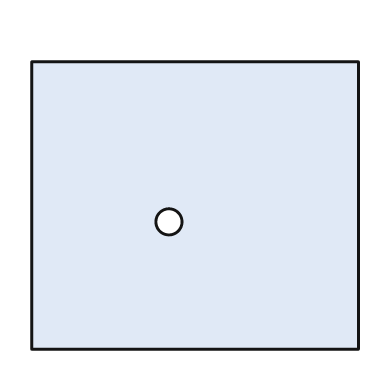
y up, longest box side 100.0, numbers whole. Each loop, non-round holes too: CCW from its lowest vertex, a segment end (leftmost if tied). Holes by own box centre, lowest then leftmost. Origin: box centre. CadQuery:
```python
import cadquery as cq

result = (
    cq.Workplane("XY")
    .moveTo(-50.0, -44.0)
    .lineTo(50.0, -44.0)
    .lineTo(50.0, 44.0)
    .lineTo(-50.0, 44.0)
    .close()
    .moveTo(-8.0, -5.0)
    .circle(4.0)
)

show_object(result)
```